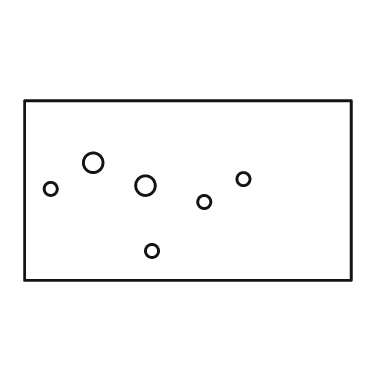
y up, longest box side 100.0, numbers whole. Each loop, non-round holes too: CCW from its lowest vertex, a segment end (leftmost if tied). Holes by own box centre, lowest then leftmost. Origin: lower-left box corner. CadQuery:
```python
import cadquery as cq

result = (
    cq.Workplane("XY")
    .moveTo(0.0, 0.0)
    .lineTo(100.0, 0.0)
    .lineTo(100.0, 55.0)
    .lineTo(0.0, 55.0)
    .close()
    .moveTo(39.0, 9.0)
    .circle(2.0)
    .moveTo(55.0, 24.0)
    .circle(2.0)
    .moveTo(8.0, 28.0)
    .circle(2.0)
    .moveTo(37.0, 29.0)
    .circle(3.0)
    .moveTo(67.0, 31.0)
    .circle(2.0)
    .moveTo(21.0, 36.0)
    .circle(3.0)
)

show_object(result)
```